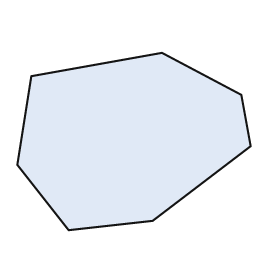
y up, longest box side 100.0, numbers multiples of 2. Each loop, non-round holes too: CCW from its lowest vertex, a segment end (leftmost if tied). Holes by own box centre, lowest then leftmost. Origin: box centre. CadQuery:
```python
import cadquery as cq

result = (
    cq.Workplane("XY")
    .moveTo(-28.0, -38.0)
    .lineTo(8.0, -34.0)
    .lineTo(50.0, -2.0)
    .lineTo(46.0, 20.0)
    .lineTo(12.0, 38.0)
    .lineTo(-44.0, 28.0)
    .lineTo(-50.0, -10.0)
    .close()
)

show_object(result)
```